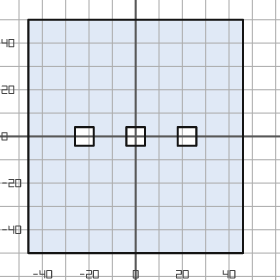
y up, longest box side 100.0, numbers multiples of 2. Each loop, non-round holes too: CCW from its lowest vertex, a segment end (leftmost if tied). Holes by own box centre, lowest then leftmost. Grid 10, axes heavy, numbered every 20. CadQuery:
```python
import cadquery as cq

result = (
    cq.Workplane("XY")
    .moveTo(-46.0, -50.0)
    .lineTo(46.0, -50.0)
    .lineTo(46.0, 50.0)
    .lineTo(-46.0, 50.0)
    .close()
    .moveTo(-26.0, -4.0)
    .lineTo(-18.0, -4.0)
    .lineTo(-18.0, 4.0)
    .lineTo(-26.0, 4.0)
    .close()
    .moveTo(-4.0, -4.0)
    .lineTo(4.0, -4.0)
    .lineTo(4.0, 4.0)
    .lineTo(-4.0, 4.0)
    .close()
    .moveTo(18.0, -4.0)
    .lineTo(26.0, -4.0)
    .lineTo(26.0, 4.0)
    .lineTo(18.0, 4.0)
    .close()
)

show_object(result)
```